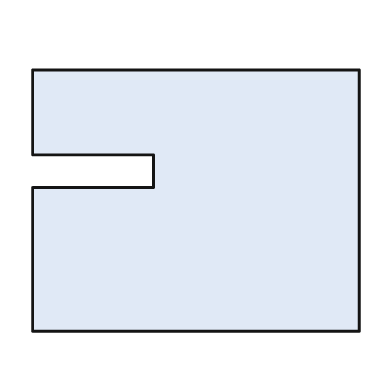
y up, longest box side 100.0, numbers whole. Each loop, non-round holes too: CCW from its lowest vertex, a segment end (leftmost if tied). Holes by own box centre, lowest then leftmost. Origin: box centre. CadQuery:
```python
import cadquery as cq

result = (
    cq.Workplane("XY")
    .moveTo(-50.0, -40.0)
    .lineTo(50.0, -40.0)
    .lineTo(50.0, 40.0)
    .lineTo(-50.0, 40.0)
    .lineTo(-50.0, 14.0)
    .lineTo(-13.0, 14.0)
    .lineTo(-13.0, 4.0)
    .lineTo(-50.0, 4.0)
    .close()
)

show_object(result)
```